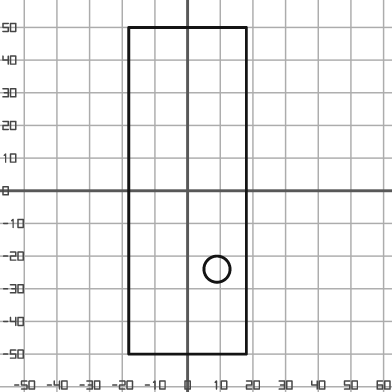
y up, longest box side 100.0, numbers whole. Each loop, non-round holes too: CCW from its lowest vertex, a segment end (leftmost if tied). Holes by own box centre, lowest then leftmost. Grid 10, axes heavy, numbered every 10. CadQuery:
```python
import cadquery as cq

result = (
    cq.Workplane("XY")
    .moveTo(-18.0, -50.0)
    .lineTo(18.0, -50.0)
    .lineTo(18.0, 50.0)
    .lineTo(-18.0, 50.0)
    .close()
    .moveTo(9.0, -24.0)
    .circle(4.0)
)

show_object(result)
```